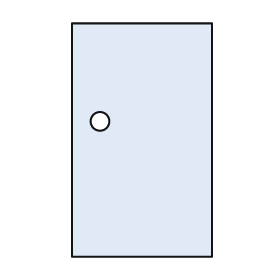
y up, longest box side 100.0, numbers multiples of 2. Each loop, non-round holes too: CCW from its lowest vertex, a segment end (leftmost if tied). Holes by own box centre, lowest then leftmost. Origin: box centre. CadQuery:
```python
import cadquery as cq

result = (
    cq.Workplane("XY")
    .moveTo(-30.0, -50.0)
    .lineTo(30.0, -50.0)
    .lineTo(30.0, 50.0)
    .lineTo(-30.0, 50.0)
    .close()
    .moveTo(-18.0, 8.0)
    .circle(4.0)
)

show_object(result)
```